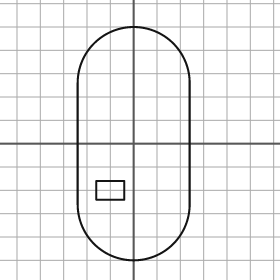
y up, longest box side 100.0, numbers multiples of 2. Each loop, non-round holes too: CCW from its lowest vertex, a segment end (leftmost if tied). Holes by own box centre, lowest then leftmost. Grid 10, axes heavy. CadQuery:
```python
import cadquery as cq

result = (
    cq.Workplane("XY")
    .moveTo(-24.0, -26.0)
    .threePointArc((0.0, -50.0), (24.0, -26.0))
    .lineTo(24.0, 26.0)
    .threePointArc((0.0, 50.0), (-24.0, 26.0))
    .close()
    .moveTo(-16.0, -24.0)
    .lineTo(-4.0, -24.0)
    .lineTo(-4.0, -16.0)
    .lineTo(-16.0, -16.0)
    .close()
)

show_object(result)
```